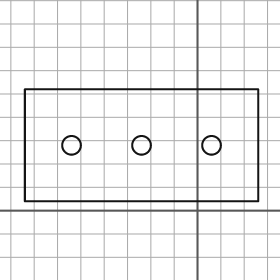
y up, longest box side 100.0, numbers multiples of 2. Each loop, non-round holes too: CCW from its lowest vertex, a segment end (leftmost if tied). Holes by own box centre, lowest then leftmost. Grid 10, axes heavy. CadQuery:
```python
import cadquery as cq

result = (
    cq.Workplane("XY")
    .moveTo(-74.0, 4.0)
    .lineTo(26.0, 4.0)
    .lineTo(26.0, 52.0)
    .lineTo(-74.0, 52.0)
    .close()
    .moveTo(-54.0, 28.0)
    .circle(4.0)
    .moveTo(-24.0, 28.0)
    .circle(4.0)
    .moveTo(6.0, 28.0)
    .circle(4.0)
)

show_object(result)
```